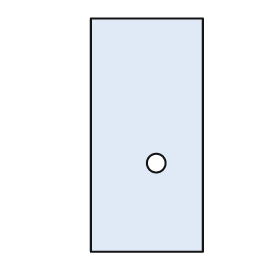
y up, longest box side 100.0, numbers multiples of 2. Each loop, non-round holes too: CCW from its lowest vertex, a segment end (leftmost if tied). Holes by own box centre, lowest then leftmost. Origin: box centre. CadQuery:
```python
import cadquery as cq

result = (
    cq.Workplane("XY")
    .moveTo(-24.0, -50.0)
    .lineTo(24.0, -50.0)
    .lineTo(24.0, 50.0)
    .lineTo(-24.0, 50.0)
    .close()
    .moveTo(4.0, -12.0)
    .circle(4.0)
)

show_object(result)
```